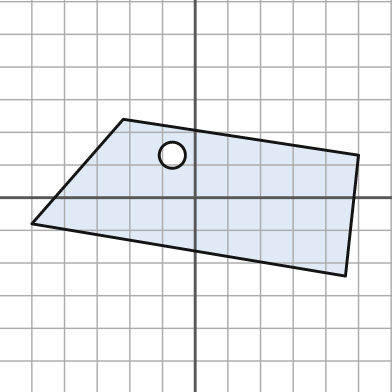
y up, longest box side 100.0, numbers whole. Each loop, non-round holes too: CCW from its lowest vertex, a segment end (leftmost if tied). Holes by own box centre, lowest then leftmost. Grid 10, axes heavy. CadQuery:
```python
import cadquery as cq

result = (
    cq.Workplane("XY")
    .moveTo(46.0, -24.0)
    .lineTo(50.0, 13.0)
    .lineTo(-22.0, 24.0)
    .lineTo(-50.0, -8.0)
    .close()
    .moveTo(-7.0, 13.0)
    .circle(4.0)
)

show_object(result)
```